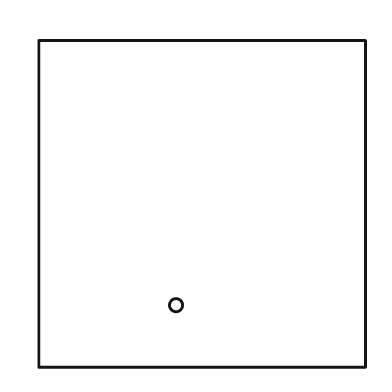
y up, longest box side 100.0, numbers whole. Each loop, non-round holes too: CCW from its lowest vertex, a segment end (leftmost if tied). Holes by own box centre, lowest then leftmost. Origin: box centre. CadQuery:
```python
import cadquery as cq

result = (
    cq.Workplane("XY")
    .moveTo(-50.0, -50.0)
    .lineTo(50.0, -50.0)
    .lineTo(50.0, 50.0)
    .lineTo(-50.0, 50.0)
    .close()
    .moveTo(-8.0, -31.0)
    .circle(2.0)
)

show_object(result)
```